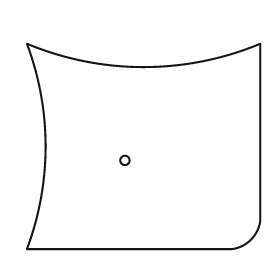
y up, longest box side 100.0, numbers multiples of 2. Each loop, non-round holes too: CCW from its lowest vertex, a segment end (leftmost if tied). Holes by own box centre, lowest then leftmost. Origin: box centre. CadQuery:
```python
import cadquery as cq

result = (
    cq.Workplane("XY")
    .moveTo(-50.0, -44.0)
    .lineTo(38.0, -44.0)
    .threePointArc((46.0, -40.0), (50.0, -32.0))
    .lineTo(50.0, 44.0)
    .threePointArc((0.0, 34.0), (-50.0, 44.0))
    .threePointArc((-42.0, 0.0), (-50.0, -44.0))
    .close()
    .moveTo(-8.0, -6.0)
    .circle(2.0)
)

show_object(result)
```